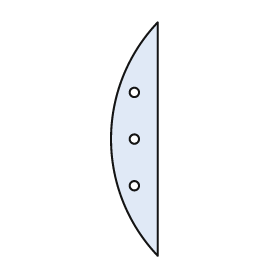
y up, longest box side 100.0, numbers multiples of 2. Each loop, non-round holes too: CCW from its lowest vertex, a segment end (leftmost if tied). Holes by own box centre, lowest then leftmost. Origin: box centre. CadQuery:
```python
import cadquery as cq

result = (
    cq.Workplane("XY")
    .moveTo(10.0, -50.0)
    .lineTo(10.0, 50.0)
    .threePointArc((-10.0, 0.0), (10.0, -50.0))
    .close()
    .moveTo(0.0, -20.0)
    .circle(2.0)
    .moveTo(0.0, 0.0)
    .circle(2.0)
    .moveTo(0.0, 20.0)
    .circle(2.0)
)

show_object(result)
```